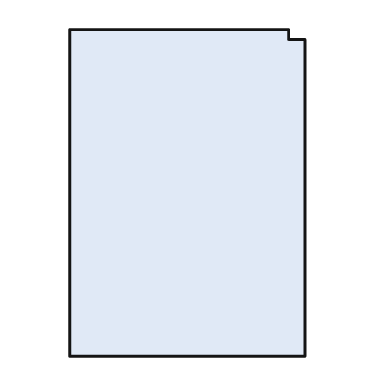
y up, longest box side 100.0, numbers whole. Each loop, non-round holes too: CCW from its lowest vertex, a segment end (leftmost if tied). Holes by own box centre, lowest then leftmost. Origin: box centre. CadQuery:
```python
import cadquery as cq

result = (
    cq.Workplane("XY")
    .moveTo(-36.0, -50.0)
    .lineTo(36.0, -50.0)
    .lineTo(36.0, 47.0)
    .lineTo(31.0, 47.0)
    .lineTo(31.0, 50.0)
    .lineTo(-36.0, 50.0)
    .close()
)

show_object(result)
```